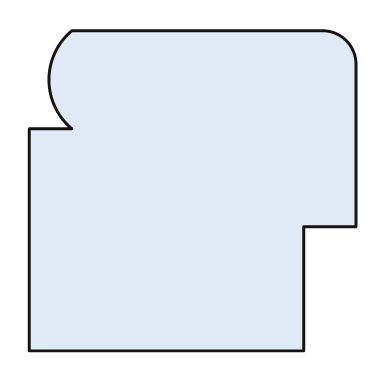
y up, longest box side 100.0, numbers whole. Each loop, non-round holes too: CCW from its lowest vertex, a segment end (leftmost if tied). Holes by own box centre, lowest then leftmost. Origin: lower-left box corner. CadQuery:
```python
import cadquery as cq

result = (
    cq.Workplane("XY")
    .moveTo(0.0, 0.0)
    .lineTo(84.0, 0.0)
    .lineTo(84.0, 38.0)
    .lineTo(100.0, 38.0)
    .lineTo(100.0, 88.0)
    .threePointArc((97.0, 95.0), (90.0, 98.0))
    .lineTo(13.0, 98.0)
    .threePointArc((6.0, 83.0), (13.0, 68.0))
    .lineTo(0.0, 68.0)
    .close()
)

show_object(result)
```